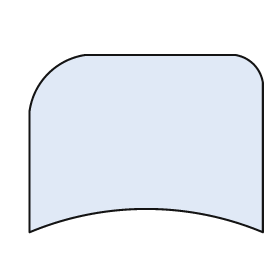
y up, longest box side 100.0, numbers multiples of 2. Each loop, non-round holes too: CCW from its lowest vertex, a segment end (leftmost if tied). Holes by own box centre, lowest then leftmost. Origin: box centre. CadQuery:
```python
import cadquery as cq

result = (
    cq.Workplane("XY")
    .moveTo(-50.0, -38.0)
    .threePointArc((0.0, -28.0), (50.0, -38.0))
    .lineTo(50.0, 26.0)
    .threePointArc((46.0, 34.0), (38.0, 38.0))
    .lineTo(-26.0, 38.0)
    .threePointArc((-42.0, 30.0), (-50.0, 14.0))
    .close()
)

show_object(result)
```